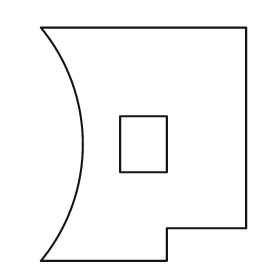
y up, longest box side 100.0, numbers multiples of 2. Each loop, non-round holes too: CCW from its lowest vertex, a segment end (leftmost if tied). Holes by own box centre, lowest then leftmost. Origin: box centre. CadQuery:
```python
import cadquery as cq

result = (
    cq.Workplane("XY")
    .moveTo(-44.0, -50.0)
    .lineTo(10.0, -50.0)
    .lineTo(10.0, -36.0)
    .lineTo(44.0, -36.0)
    .lineTo(44.0, 50.0)
    .lineTo(-44.0, 50.0)
    .threePointArc((-26.0, 0.0), (-44.0, -50.0))
    .close()
    .moveTo(-10.0, -12.0)
    .lineTo(10.0, -12.0)
    .lineTo(10.0, 12.0)
    .lineTo(-10.0, 12.0)
    .close()
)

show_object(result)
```